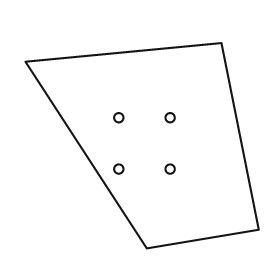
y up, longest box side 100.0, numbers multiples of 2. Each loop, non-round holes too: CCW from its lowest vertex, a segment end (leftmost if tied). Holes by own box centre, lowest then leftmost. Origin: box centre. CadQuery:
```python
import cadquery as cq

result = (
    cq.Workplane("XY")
    .moveTo(2.0, -44.0)
    .lineTo(50.0, -36.0)
    .lineTo(34.0, 44.0)
    .lineTo(-50.0, 36.0)
    .close()
    .moveTo(-10.0, -10.0)
    .circle(2.0)
    .moveTo(12.0, -10.0)
    .circle(2.0)
    .moveTo(-10.0, 12.0)
    .circle(2.0)
    .moveTo(12.0, 12.0)
    .circle(2.0)
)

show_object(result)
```